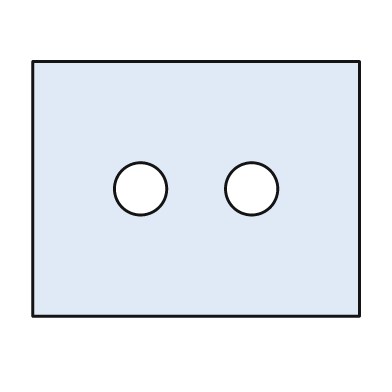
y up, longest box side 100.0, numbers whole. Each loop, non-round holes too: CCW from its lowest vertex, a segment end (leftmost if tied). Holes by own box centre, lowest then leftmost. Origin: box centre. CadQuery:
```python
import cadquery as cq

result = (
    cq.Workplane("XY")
    .moveTo(-50.0, -39.0)
    .lineTo(50.0, -39.0)
    .lineTo(50.0, 39.0)
    .lineTo(-50.0, 39.0)
    .close()
    .moveTo(-17.0, 0.0)
    .circle(8.0)
    .moveTo(17.0, 0.0)
    .circle(8.0)
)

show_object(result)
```